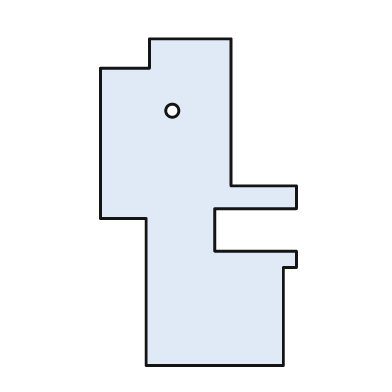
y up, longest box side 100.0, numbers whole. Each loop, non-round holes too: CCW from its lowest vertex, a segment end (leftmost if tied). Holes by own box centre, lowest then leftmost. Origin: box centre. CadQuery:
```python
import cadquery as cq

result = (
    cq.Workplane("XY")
    .moveTo(-16.0, -50.0)
    .lineTo(26.0, -50.0)
    .lineTo(26.0, -20.0)
    .lineTo(30.0, -20.0)
    .lineTo(30.0, -15.0)
    .lineTo(5.0, -15.0)
    .lineTo(5.0, -2.0)
    .lineTo(30.0, -2.0)
    .lineTo(30.0, 5.0)
    .lineTo(10.0, 5.0)
    .lineTo(10.0, 50.0)
    .lineTo(-15.0, 50.0)
    .lineTo(-15.0, 41.0)
    .lineTo(-30.0, 41.0)
    .lineTo(-30.0, -5.0)
    .lineTo(-16.0, -5.0)
    .close()
    .moveTo(-8.0, 28.0)
    .circle(2.0)
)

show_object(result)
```